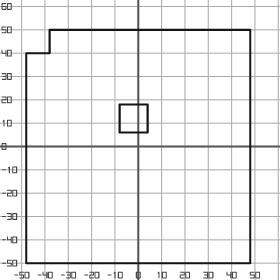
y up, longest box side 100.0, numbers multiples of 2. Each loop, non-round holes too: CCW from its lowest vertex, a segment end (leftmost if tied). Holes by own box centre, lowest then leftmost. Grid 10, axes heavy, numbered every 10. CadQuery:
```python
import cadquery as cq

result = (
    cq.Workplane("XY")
    .moveTo(-48.0, -50.0)
    .lineTo(48.0, -50.0)
    .lineTo(48.0, 50.0)
    .lineTo(-38.0, 50.0)
    .lineTo(-38.0, 40.0)
    .lineTo(-48.0, 40.0)
    .close()
    .moveTo(-8.0, 6.0)
    .lineTo(4.0, 6.0)
    .lineTo(4.0, 18.0)
    .lineTo(-8.0, 18.0)
    .close()
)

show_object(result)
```